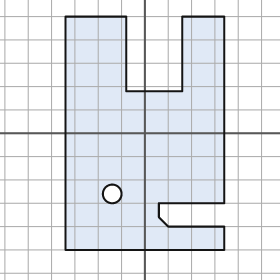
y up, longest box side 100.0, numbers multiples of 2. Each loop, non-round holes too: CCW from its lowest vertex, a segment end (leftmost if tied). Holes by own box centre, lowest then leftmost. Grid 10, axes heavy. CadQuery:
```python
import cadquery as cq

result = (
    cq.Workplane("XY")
    .moveTo(-34.0, -50.0)
    .lineTo(34.0, -50.0)
    .lineTo(34.0, -40.0)
    .lineTo(10.0, -40.0)
    .lineTo(6.0, -36.0)
    .lineTo(6.0, -30.0)
    .lineTo(34.0, -30.0)
    .lineTo(34.0, 50.0)
    .lineTo(16.0, 50.0)
    .lineTo(16.0, 18.0)
    .lineTo(-8.0, 18.0)
    .lineTo(-8.0, 50.0)
    .lineTo(-34.0, 50.0)
    .close()
    .moveTo(-14.0, -26.0)
    .circle(4.0)
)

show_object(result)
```